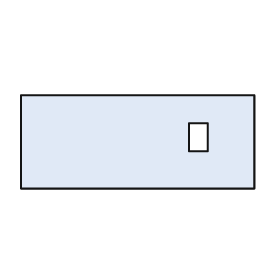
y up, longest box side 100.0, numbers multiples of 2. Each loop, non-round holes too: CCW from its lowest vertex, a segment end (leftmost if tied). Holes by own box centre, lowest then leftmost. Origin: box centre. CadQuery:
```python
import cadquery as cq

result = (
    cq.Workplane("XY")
    .moveTo(-50.0, -20.0)
    .lineTo(50.0, -20.0)
    .lineTo(50.0, 20.0)
    .lineTo(-50.0, 20.0)
    .close()
    .moveTo(22.0, -4.0)
    .lineTo(30.0, -4.0)
    .lineTo(30.0, 8.0)
    .lineTo(22.0, 8.0)
    .close()
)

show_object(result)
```